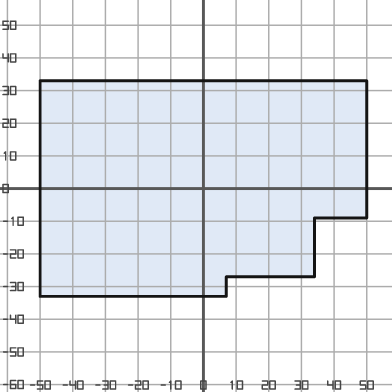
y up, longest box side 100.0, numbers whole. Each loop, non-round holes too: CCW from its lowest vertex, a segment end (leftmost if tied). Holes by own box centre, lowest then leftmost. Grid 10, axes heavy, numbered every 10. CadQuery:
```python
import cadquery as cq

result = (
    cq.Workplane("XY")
    .moveTo(-50.0, -33.0)
    .lineTo(7.0, -33.0)
    .lineTo(7.0, -27.0)
    .lineTo(34.0, -27.0)
    .lineTo(34.0, -9.0)
    .lineTo(50.0, -9.0)
    .lineTo(50.0, 33.0)
    .lineTo(-50.0, 33.0)
    .close()
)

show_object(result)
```